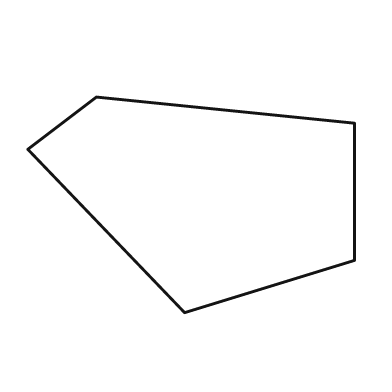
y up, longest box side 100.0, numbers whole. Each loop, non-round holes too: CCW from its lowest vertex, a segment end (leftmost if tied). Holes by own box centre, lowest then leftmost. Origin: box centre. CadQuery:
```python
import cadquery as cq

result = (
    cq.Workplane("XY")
    .moveTo(-2.0, -33.0)
    .lineTo(50.0, -17.0)
    .lineTo(50.0, 25.0)
    .lineTo(-29.0, 33.0)
    .lineTo(-50.0, 17.0)
    .close()
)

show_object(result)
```